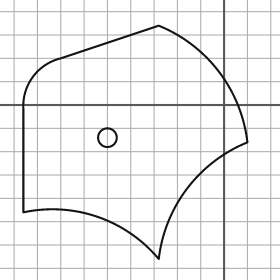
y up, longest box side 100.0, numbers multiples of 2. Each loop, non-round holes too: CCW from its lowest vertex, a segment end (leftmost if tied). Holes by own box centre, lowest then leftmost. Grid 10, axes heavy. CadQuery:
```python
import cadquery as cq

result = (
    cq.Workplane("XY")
    .moveTo(-28.0, -66.0)
    .threePointArc((-16.0, -36.0), (10.0, -16.0))
    .threePointArc((-2.0, 14.0), (-28.0, 34.0))
    .lineTo(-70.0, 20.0)
    .threePointArc((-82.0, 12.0), (-86.0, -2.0))
    .lineTo(-86.0, -46.0)
    .threePointArc((-54.0, -48.0), (-28.0, -66.0))
    .close()
    .moveTo(-50.0, -14.0)
    .circle(4.0)
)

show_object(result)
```